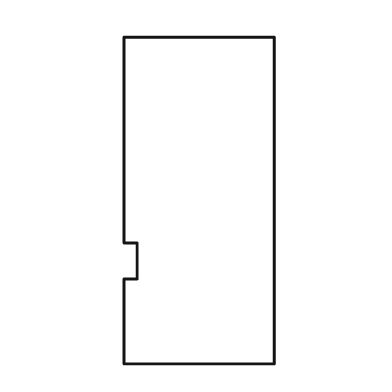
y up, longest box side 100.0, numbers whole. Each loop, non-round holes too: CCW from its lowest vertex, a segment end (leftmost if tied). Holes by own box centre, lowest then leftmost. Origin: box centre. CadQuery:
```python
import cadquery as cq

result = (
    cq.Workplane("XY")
    .moveTo(-23.0, -50.0)
    .lineTo(23.0, -50.0)
    .lineTo(23.0, 50.0)
    .lineTo(-23.0, 50.0)
    .lineTo(-23.0, -13.0)
    .lineTo(-19.0, -13.0)
    .lineTo(-19.0, -24.0)
    .lineTo(-23.0, -24.0)
    .close()
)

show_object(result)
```